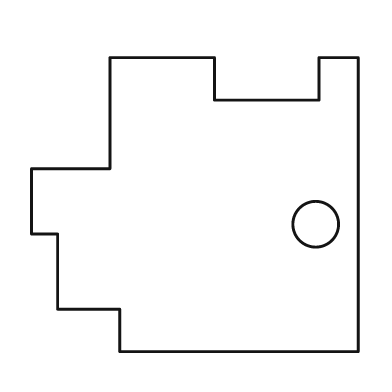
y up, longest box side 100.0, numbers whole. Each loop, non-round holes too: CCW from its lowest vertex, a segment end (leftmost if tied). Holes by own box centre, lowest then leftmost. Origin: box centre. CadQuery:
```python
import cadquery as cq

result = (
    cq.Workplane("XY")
    .moveTo(-23.0, -45.0)
    .lineTo(50.0, -45.0)
    .lineTo(50.0, 45.0)
    .lineTo(38.0, 45.0)
    .lineTo(38.0, 32.0)
    .lineTo(6.0, 32.0)
    .lineTo(6.0, 45.0)
    .lineTo(-26.0, 45.0)
    .lineTo(-26.0, 11.0)
    .lineTo(-50.0, 11.0)
    .lineTo(-50.0, -9.0)
    .lineTo(-42.0, -9.0)
    .lineTo(-42.0, -32.0)
    .lineTo(-23.0, -32.0)
    .close()
    .moveTo(37.0, -6.0)
    .circle(7.0)
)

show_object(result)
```